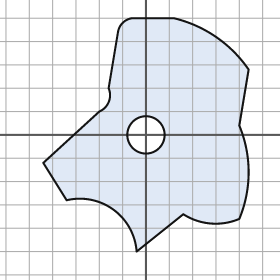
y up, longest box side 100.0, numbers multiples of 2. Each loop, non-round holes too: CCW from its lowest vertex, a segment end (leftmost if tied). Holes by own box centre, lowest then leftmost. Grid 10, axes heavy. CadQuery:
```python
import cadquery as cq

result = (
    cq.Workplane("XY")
    .moveTo(-4.0, -50.0)
    .lineTo(16.0, -34.0)
    .threePointArc((28.0, -38.0), (40.0, -36.0))
    .threePointArc((44.0, -16.0), (40.0, 4.0))
    .lineTo(44.0, 28.0)
    .threePointArc((30.0, 42.0), (12.0, 50.0))
    .lineTo(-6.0, 50.0)
    .threePointArc((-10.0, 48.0), (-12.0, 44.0))
    .lineTo(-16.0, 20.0)
    .threePointArc((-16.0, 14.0), (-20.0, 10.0))
    .lineTo(-44.0, -12.0)
    .lineTo(-34.0, -28.0)
    .threePointArc((-14.0, -32.0), (-4.0, -50.0))
    .close()
    .moveTo(0.0, 0.0)
    .circle(8.0)
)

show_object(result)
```